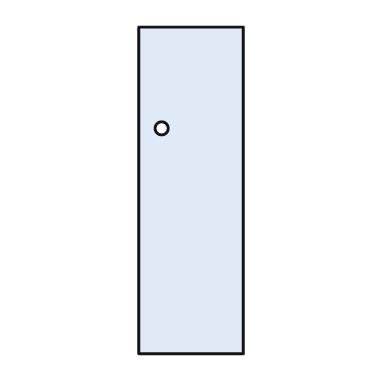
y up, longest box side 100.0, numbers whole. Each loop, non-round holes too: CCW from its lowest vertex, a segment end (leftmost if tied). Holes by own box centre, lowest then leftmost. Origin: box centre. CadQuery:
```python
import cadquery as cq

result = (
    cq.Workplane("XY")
    .moveTo(-16.0, -50.0)
    .lineTo(16.0, -50.0)
    .lineTo(16.0, 50.0)
    .lineTo(-16.0, 50.0)
    .close()
    .moveTo(-9.0, 19.0)
    .circle(2.0)
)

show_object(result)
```